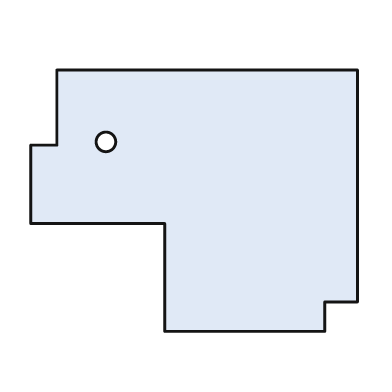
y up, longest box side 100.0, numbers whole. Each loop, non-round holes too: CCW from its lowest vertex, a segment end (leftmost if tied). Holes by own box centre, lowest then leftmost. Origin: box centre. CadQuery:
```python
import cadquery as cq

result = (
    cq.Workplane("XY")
    .moveTo(-9.0, -40.0)
    .lineTo(40.0, -40.0)
    .lineTo(40.0, -31.0)
    .lineTo(50.0, -31.0)
    .lineTo(50.0, 40.0)
    .lineTo(-42.0, 40.0)
    .lineTo(-42.0, 17.0)
    .lineTo(-50.0, 17.0)
    .lineTo(-50.0, -7.0)
    .lineTo(-9.0, -7.0)
    .close()
    .moveTo(-27.0, 18.0)
    .circle(3.0)
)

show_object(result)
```